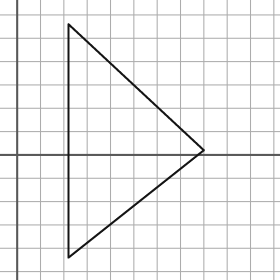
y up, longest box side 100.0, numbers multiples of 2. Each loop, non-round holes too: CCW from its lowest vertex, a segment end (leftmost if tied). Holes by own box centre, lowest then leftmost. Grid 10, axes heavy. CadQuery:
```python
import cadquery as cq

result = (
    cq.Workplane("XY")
    .moveTo(22.0, -44.0)
    .lineTo(80.0, 2.0)
    .lineTo(22.0, 56.0)
    .close()
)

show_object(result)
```